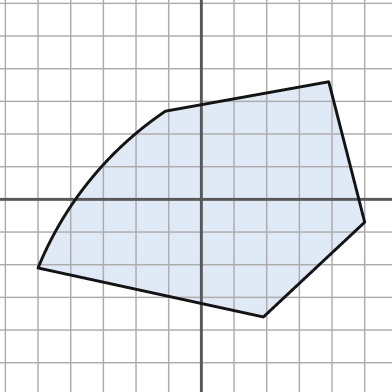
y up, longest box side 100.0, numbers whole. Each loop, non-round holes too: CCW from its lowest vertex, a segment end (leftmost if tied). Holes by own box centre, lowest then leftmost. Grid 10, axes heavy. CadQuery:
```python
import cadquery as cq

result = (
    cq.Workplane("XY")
    .moveTo(19.0, -36.0)
    .lineTo(50.0, -7.0)
    .lineTo(39.0, 36.0)
    .lineTo(-11.0, 27.0)
    .threePointArc((-34.0, 6.0), (-50.0, -21.0))
    .close()
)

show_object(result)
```